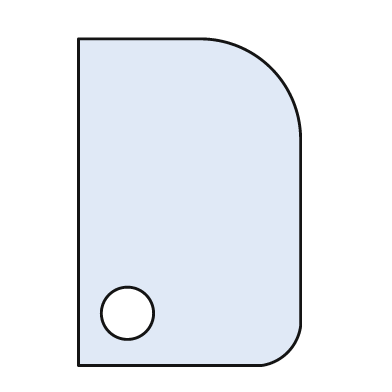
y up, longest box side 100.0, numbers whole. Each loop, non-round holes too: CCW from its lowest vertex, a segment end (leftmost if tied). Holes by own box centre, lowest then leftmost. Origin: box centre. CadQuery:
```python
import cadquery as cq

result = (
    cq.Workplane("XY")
    .moveTo(-34.0, -50.0)
    .lineTo(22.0, -50.0)
    .threePointArc((30.0, -46.0), (34.0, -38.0))
    .lineTo(34.0, 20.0)
    .threePointArc((25.0, 41.0), (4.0, 50.0))
    .lineTo(-34.0, 50.0)
    .close()
    .moveTo(-19.0, -34.0)
    .circle(8.0)
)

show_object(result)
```